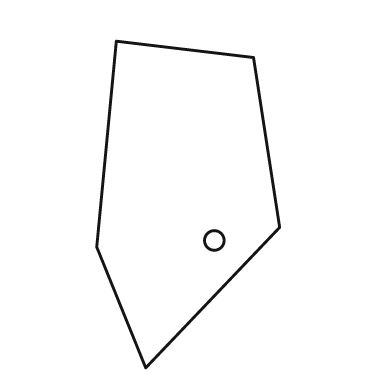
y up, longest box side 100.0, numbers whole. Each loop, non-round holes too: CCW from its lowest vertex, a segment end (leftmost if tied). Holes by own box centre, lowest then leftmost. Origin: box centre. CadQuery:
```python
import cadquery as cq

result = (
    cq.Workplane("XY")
    .moveTo(-13.0, -50.0)
    .lineTo(28.0, -7.0)
    .lineTo(20.0, 45.0)
    .lineTo(-22.0, 50.0)
    .lineTo(-28.0, -13.0)
    .close()
    .moveTo(8.0, -11.0)
    .circle(3.0)
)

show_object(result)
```